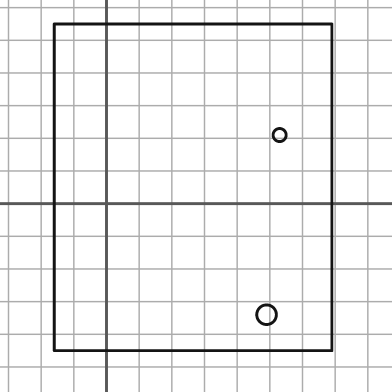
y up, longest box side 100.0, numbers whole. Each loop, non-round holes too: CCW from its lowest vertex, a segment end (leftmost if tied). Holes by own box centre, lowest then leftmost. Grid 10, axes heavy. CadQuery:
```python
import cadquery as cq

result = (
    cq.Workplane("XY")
    .moveTo(-16.0, -45.0)
    .lineTo(69.0, -45.0)
    .lineTo(69.0, 55.0)
    .lineTo(-16.0, 55.0)
    .close()
    .moveTo(49.0, -34.0)
    .circle(3.0)
    .moveTo(53.0, 21.0)
    .circle(2.0)
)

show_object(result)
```